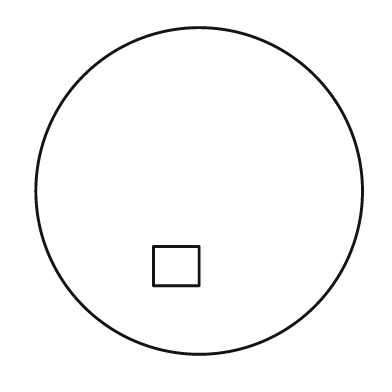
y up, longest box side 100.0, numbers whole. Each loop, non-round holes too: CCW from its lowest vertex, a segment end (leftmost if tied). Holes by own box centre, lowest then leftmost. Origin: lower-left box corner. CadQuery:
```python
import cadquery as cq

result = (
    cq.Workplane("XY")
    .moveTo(50.0, 50.0)
    .circle(50.0)
    .moveTo(36.0, 21.0)
    .lineTo(50.0, 21.0)
    .lineTo(50.0, 33.0)
    .lineTo(36.0, 33.0)
    .close()
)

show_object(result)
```